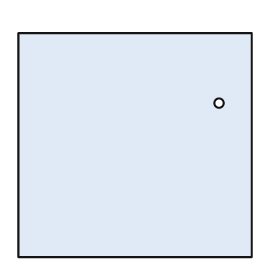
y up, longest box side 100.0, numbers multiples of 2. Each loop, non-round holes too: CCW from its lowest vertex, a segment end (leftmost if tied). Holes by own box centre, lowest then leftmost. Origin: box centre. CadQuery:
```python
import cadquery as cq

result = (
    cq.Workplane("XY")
    .moveTo(-50.0, -48.0)
    .lineTo(50.0, -48.0)
    .lineTo(50.0, 48.0)
    .lineTo(-50.0, 48.0)
    .close()
    .moveTo(36.0, 18.0)
    .circle(2.0)
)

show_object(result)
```